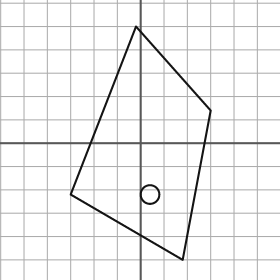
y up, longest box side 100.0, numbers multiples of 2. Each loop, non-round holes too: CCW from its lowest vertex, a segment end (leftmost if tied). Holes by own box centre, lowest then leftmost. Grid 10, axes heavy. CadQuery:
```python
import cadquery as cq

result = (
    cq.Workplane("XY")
    .moveTo(18.0, -50.0)
    .lineTo(30.0, 14.0)
    .lineTo(-2.0, 50.0)
    .lineTo(-30.0, -22.0)
    .close()
    .moveTo(4.0, -22.0)
    .circle(4.0)
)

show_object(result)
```